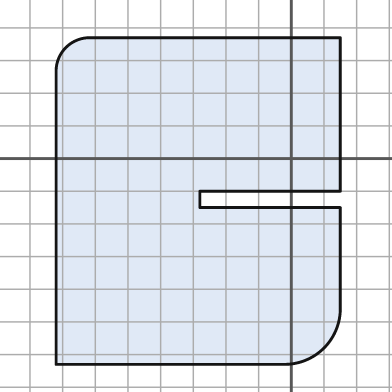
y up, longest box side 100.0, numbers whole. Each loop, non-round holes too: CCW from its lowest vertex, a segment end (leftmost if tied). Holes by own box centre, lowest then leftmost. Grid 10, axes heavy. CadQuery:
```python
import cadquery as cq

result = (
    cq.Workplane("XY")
    .moveTo(-72.0, -63.0)
    .lineTo(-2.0, -63.0)
    .threePointArc((10.0, -58.0), (15.0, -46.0))
    .lineTo(15.0, -15.0)
    .lineTo(-28.0, -15.0)
    .lineTo(-28.0, -10.0)
    .lineTo(15.0, -10.0)
    .lineTo(15.0, 37.0)
    .lineTo(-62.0, 37.0)
    .threePointArc((-69.0, 34.0), (-72.0, 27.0))
    .close()
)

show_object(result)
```